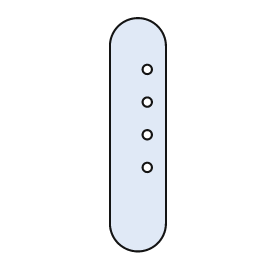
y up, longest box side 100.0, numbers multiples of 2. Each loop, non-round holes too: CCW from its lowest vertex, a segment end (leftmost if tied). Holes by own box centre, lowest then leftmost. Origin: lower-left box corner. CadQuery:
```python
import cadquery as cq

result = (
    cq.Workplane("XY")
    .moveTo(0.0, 12.0)
    .threePointArc((12.0, 0.0), (24.0, 12.0))
    .lineTo(24.0, 88.0)
    .threePointArc((12.0, 100.0), (0.0, 88.0))
    .close()
    .moveTo(16.0, 36.0)
    .circle(2.0)
    .moveTo(16.0, 50.0)
    .circle(2.0)
    .moveTo(16.0, 64.0)
    .circle(2.0)
    .moveTo(16.0, 78.0)
    .circle(2.0)
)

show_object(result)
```